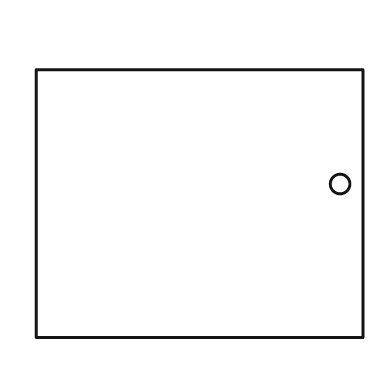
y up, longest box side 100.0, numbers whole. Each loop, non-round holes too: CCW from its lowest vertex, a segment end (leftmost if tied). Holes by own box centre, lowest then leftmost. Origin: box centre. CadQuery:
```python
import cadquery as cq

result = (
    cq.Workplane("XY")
    .moveTo(-50.0, -41.0)
    .lineTo(50.0, -41.0)
    .lineTo(50.0, 41.0)
    .lineTo(-50.0, 41.0)
    .close()
    .moveTo(43.0, 6.0)
    .circle(3.0)
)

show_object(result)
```